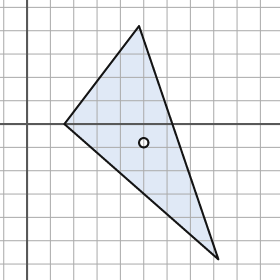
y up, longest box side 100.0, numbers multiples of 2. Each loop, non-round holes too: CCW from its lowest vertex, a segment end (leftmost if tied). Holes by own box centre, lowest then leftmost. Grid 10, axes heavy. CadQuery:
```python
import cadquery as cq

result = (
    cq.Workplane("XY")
    .moveTo(82.0, -58.0)
    .lineTo(48.0, 42.0)
    .lineTo(16.0, 0.0)
    .close()
    .moveTo(50.0, -8.0)
    .circle(2.0)
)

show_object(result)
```